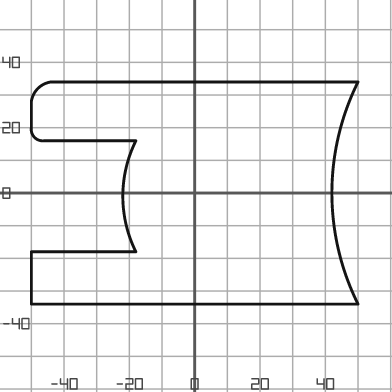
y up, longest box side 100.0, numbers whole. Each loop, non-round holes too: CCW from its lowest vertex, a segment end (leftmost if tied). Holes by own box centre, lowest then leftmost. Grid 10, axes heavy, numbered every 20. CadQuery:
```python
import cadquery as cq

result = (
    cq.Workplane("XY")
    .moveTo(-50.0, -34.0)
    .lineTo(50.0, -34.0)
    .threePointArc((42.0, 0.0), (50.0, 34.0))
    .lineTo(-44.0, 34.0)
    .threePointArc((-48.0, 32.0), (-50.0, 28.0))
    .lineTo(-50.0, 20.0)
    .threePointArc((-49.0, 17.0), (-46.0, 16.0))
    .lineTo(-18.0, 16.0)
    .threePointArc((-22.0, -1.0), (-18.0, -18.0))
    .lineTo(-50.0, -18.0)
    .close()
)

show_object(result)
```